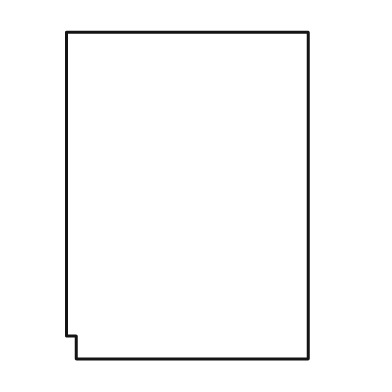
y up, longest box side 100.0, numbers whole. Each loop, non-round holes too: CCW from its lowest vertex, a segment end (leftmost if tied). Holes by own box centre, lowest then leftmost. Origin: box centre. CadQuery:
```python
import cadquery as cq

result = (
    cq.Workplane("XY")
    .moveTo(-34.0, -50.0)
    .lineTo(37.0, -50.0)
    .lineTo(37.0, 50.0)
    .lineTo(-37.0, 50.0)
    .lineTo(-37.0, -43.0)
    .lineTo(-34.0, -43.0)
    .close()
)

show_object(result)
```